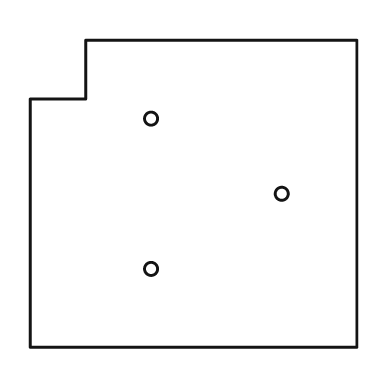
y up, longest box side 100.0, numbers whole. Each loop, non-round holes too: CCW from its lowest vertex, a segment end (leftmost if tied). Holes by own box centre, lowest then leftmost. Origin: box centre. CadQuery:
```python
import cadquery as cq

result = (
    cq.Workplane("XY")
    .moveTo(-50.0, -47.0)
    .lineTo(50.0, -47.0)
    .lineTo(50.0, 47.0)
    .lineTo(-33.0, 47.0)
    .lineTo(-33.0, 29.0)
    .lineTo(-50.0, 29.0)
    .close()
    .moveTo(-13.0, -23.0)
    .circle(2.0)
    .moveTo(27.0, 0.0)
    .circle(2.0)
    .moveTo(-13.0, 23.0)
    .circle(2.0)
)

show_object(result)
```